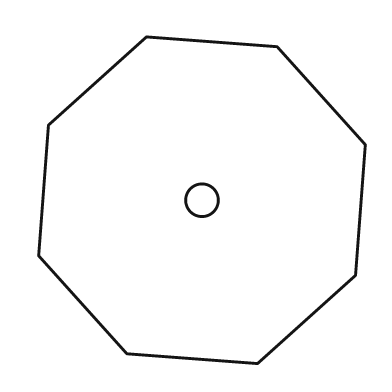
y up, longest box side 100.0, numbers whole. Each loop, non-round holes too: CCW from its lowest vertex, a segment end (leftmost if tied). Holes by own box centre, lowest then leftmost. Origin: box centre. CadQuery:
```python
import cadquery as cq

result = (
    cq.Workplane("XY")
    .moveTo(17.0, -50.0)
    .lineTo(47.0, -23.0)
    .lineTo(50.0, 17.0)
    .lineTo(23.0, 47.0)
    .lineTo(-17.0, 50.0)
    .lineTo(-47.0, 23.0)
    .lineTo(-50.0, -17.0)
    .lineTo(-23.0, -47.0)
    .close()
    .moveTo(0.0, 0.0)
    .circle(5.0)
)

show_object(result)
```